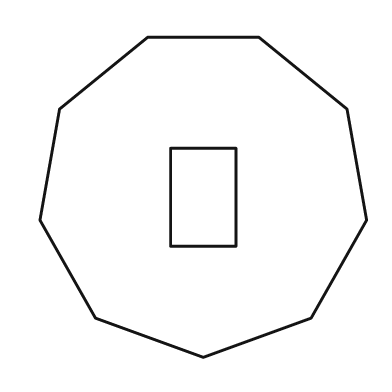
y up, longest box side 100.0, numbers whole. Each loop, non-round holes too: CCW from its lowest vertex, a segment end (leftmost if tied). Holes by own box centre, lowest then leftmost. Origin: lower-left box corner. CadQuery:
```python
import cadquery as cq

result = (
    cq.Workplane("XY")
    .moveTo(50.0, 0.0)
    .lineTo(83.0, 12.0)
    .lineTo(100.0, 42.0)
    .lineTo(94.0, 76.0)
    .lineTo(67.0, 98.0)
    .lineTo(33.0, 98.0)
    .lineTo(6.0, 76.0)
    .lineTo(0.0, 42.0)
    .lineTo(17.0, 12.0)
    .close()
    .moveTo(40.0, 34.0)
    .lineTo(60.0, 34.0)
    .lineTo(60.0, 64.0)
    .lineTo(40.0, 64.0)
    .close()
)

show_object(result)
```